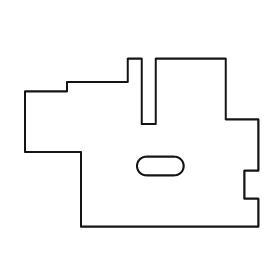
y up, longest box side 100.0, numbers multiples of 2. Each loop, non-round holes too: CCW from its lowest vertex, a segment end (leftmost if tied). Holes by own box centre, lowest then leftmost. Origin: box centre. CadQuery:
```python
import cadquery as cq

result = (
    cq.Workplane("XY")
    .moveTo(-26.0, -36.0)
    .lineTo(50.0, -36.0)
    .lineTo(50.0, -24.0)
    .lineTo(44.0, -24.0)
    .lineTo(44.0, -12.0)
    .lineTo(50.0, -12.0)
    .lineTo(50.0, 10.0)
    .lineTo(36.0, 10.0)
    .lineTo(36.0, 36.0)
    .lineTo(6.0, 36.0)
    .lineTo(6.0, 8.0)
    .lineTo(0.0, 8.0)
    .lineTo(0.0, 36.0)
    .lineTo(-6.0, 36.0)
    .lineTo(-6.0, 26.0)
    .lineTo(-32.0, 26.0)
    .lineTo(-32.0, 22.0)
    .lineTo(-50.0, 22.0)
    .lineTo(-50.0, -4.0)
    .lineTo(-26.0, -4.0)
    .close()
    .moveTo(2.0, -14.0)
    .lineTo(14.0, -14.0)
    .threePointArc((18.0, -10.0), (14.0, -6.0))
    .lineTo(2.0, -6.0)
    .threePointArc((-2.0, -10.0), (2.0, -14.0))
    .close()
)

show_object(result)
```